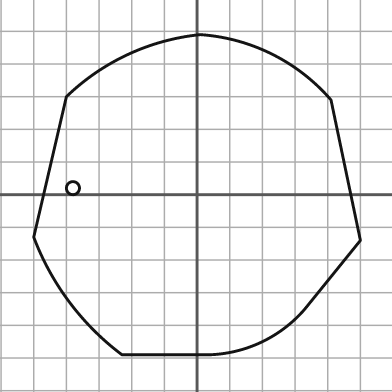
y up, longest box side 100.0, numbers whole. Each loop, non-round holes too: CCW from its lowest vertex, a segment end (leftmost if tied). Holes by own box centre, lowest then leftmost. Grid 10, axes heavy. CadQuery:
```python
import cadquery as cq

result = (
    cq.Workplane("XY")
    .moveTo(-23.0, -49.0)
    .lineTo(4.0, -49.0)
    .threePointArc((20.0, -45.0), (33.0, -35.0))
    .lineTo(50.0, -14.0)
    .lineTo(41.0, 29.0)
    .threePointArc((23.0, 43.0), (1.0, 49.0))
    .threePointArc((-21.0, 43.0), (-40.0, 30.0))
    .lineTo(-50.0, -13.0)
    .threePointArc((-39.0, -33.0), (-23.0, -49.0))
    .close()
    .moveTo(-38.0, 2.0)
    .circle(2.0)
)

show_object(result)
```